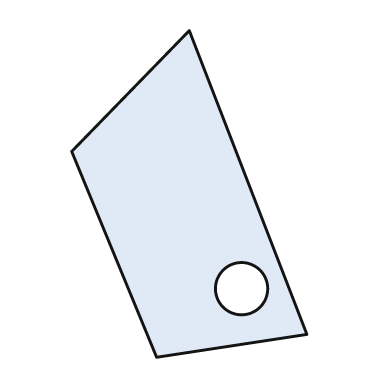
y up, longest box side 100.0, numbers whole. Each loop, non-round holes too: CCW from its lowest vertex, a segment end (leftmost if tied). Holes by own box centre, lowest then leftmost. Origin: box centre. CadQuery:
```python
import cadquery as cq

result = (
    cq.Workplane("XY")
    .moveTo(-10.0, -50.0)
    .lineTo(36.0, -43.0)
    .lineTo(0.0, 50.0)
    .lineTo(-36.0, 13.0)
    .close()
    .moveTo(16.0, -29.0)
    .circle(8.0)
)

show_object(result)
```